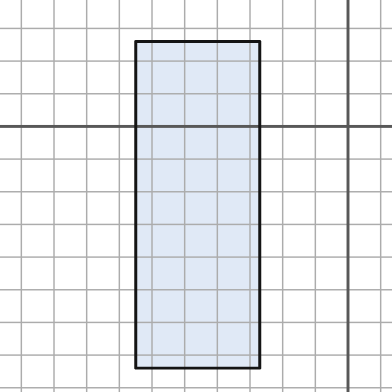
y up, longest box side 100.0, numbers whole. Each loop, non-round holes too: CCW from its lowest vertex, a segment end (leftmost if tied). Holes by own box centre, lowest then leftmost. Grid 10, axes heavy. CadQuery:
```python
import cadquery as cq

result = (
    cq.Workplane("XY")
    .moveTo(-65.0, -74.0)
    .lineTo(-27.0, -74.0)
    .lineTo(-27.0, 26.0)
    .lineTo(-65.0, 26.0)
    .close()
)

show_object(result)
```